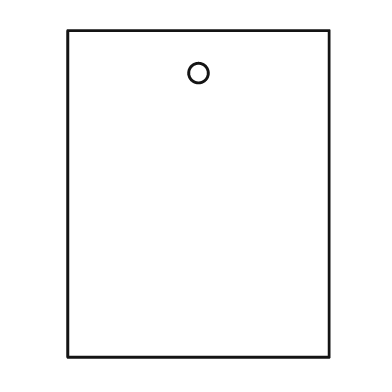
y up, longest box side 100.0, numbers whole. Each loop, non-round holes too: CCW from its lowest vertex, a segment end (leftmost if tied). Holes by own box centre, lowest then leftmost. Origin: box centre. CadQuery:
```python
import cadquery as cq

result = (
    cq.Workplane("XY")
    .moveTo(-40.0, -50.0)
    .lineTo(40.0, -50.0)
    .lineTo(40.0, 50.0)
    .lineTo(-40.0, 50.0)
    .close()
    .moveTo(0.0, 37.0)
    .circle(3.0)
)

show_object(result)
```